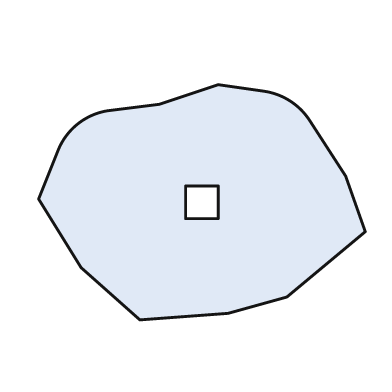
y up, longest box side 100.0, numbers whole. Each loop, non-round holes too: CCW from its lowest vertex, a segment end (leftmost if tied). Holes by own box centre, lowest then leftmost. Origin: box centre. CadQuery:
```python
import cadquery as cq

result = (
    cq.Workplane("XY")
    .moveTo(-19.0, -36.0)
    .lineTo(8.0, -34.0)
    .lineTo(26.0, -29.0)
    .lineTo(50.0, -9.0)
    .lineTo(44.0, 8.0)
    .lineTo(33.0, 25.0)
    .threePointArc((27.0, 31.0), (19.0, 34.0))
    .lineTo(5.0, 36.0)
    .lineTo(-13.0, 30.0)
    .lineTo(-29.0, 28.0)
    .threePointArc((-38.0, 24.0), (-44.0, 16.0))
    .lineTo(-50.0, 1.0)
    .lineTo(-37.0, -20.0)
    .close()
    .moveTo(-5.0, -5.0)
    .lineTo(5.0, -5.0)
    .lineTo(5.0, 5.0)
    .lineTo(-5.0, 5.0)
    .close()
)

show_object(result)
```